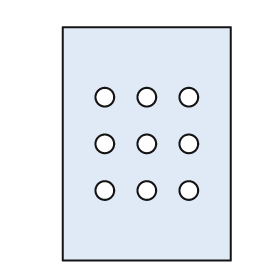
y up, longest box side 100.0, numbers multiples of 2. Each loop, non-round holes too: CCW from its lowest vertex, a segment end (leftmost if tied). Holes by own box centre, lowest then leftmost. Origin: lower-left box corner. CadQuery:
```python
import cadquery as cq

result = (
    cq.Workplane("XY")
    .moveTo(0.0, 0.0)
    .lineTo(72.0, 0.0)
    .lineTo(72.0, 100.0)
    .lineTo(0.0, 100.0)
    .close()
    .moveTo(18.0, 30.0)
    .circle(4.0)
    .moveTo(36.0, 30.0)
    .circle(4.0)
    .moveTo(54.0, 30.0)
    .circle(4.0)
    .moveTo(18.0, 50.0)
    .circle(4.0)
    .moveTo(36.0, 50.0)
    .circle(4.0)
    .moveTo(54.0, 50.0)
    .circle(4.0)
    .moveTo(18.0, 70.0)
    .circle(4.0)
    .moveTo(36.0, 70.0)
    .circle(4.0)
    .moveTo(54.0, 70.0)
    .circle(4.0)
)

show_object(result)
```